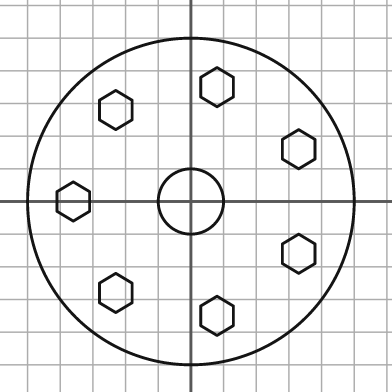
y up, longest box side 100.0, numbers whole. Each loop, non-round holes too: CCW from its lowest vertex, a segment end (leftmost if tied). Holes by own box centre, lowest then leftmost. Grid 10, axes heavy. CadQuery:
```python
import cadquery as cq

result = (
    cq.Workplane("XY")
    .moveTo(0.0, 0.0)
    .circle(50.0)
    .moveTo(8.0, -41.0)
    .lineTo(13.0, -38.0)
    .lineTo(13.0, -32.0)
    .lineTo(8.0, -29.0)
    .lineTo(3.0, -32.0)
    .lineTo(3.0, -38.0)
    .close()
    .moveTo(-23.0, -34.0)
    .lineTo(-18.0, -31.0)
    .lineTo(-18.0, -25.0)
    .lineTo(-23.0, -22.0)
    .lineTo(-28.0, -25.0)
    .lineTo(-28.0, -31.0)
    .close()
    .moveTo(33.0, -22.0)
    .lineTo(38.0, -19.0)
    .lineTo(38.0, -13.0)
    .lineTo(33.0, -10.0)
    .lineTo(28.0, -13.0)
    .lineTo(28.0, -19.0)
    .close()
    .moveTo(-36.0, -6.0)
    .lineTo(-31.0, -3.0)
    .lineTo(-31.0, 3.0)
    .lineTo(-36.0, 6.0)
    .lineTo(-41.0, 3.0)
    .lineTo(-41.0, -3.0)
    .close()
    .moveTo(0.0, 0.0)
    .circle(10.0)
    .moveTo(33.0, 10.0)
    .lineTo(38.0, 13.0)
    .lineTo(38.0, 19.0)
    .lineTo(33.0, 22.0)
    .lineTo(28.0, 19.0)
    .lineTo(28.0, 13.0)
    .close()
    .moveTo(-23.0, 22.0)
    .lineTo(-18.0, 25.0)
    .lineTo(-18.0, 31.0)
    .lineTo(-23.0, 34.0)
    .lineTo(-28.0, 31.0)
    .lineTo(-28.0, 25.0)
    .close()
    .moveTo(8.0, 29.0)
    .lineTo(13.0, 32.0)
    .lineTo(13.0, 38.0)
    .lineTo(8.0, 41.0)
    .lineTo(3.0, 38.0)
    .lineTo(3.0, 32.0)
    .close()
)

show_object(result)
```